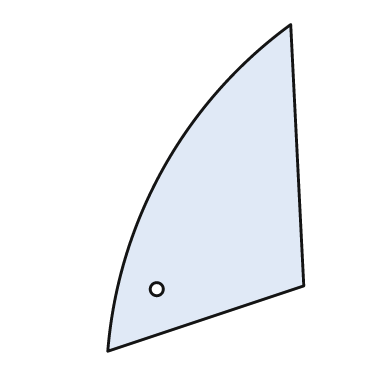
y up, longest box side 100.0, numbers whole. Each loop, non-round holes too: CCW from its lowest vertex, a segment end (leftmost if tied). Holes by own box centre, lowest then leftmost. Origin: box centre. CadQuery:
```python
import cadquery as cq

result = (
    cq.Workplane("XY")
    .moveTo(-30.0, -50.0)
    .lineTo(30.0, -30.0)
    .lineTo(26.0, 50.0)
    .threePointArc((-13.0, 6.0), (-30.0, -50.0))
    .close()
    .moveTo(-15.0, -31.0)
    .circle(2.0)
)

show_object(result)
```